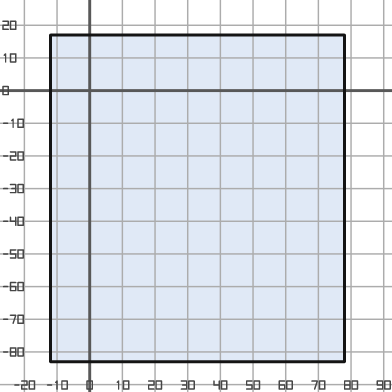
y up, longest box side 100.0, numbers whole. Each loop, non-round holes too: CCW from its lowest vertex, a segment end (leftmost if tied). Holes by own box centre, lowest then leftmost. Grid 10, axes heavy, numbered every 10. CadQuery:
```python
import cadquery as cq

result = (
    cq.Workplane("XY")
    .moveTo(-12.0, -83.0)
    .lineTo(78.0, -83.0)
    .lineTo(78.0, 17.0)
    .lineTo(-12.0, 17.0)
    .close()
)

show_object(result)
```